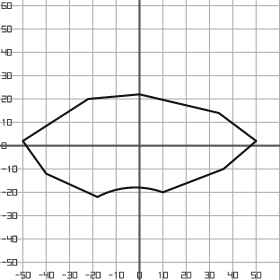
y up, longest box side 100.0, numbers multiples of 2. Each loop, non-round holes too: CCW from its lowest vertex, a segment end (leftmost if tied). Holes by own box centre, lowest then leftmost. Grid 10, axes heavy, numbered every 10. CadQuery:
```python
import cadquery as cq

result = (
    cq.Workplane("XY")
    .moveTo(-18.0, -22.0)
    .threePointArc((-4.0, -18.0), (10.0, -20.0))
    .lineTo(36.0, -10.0)
    .lineTo(50.0, 2.0)
    .lineTo(34.0, 14.0)
    .lineTo(0.0, 22.0)
    .lineTo(-22.0, 20.0)
    .lineTo(-50.0, 2.0)
    .lineTo(-40.0, -12.0)
    .close()
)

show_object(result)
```